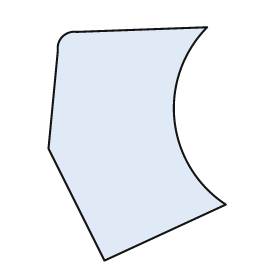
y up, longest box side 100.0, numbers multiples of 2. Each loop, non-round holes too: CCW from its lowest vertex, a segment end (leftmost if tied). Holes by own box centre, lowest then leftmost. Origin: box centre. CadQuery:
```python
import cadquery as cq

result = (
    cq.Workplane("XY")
    .moveTo(-14.0, -50.0)
    .lineTo(38.0, -26.0)
    .threePointArc((16.0, 10.0), (30.0, 50.0))
    .lineTo(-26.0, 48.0)
    .threePointArc((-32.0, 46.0), (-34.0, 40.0))
    .lineTo(-38.0, -2.0)
    .close()
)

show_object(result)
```